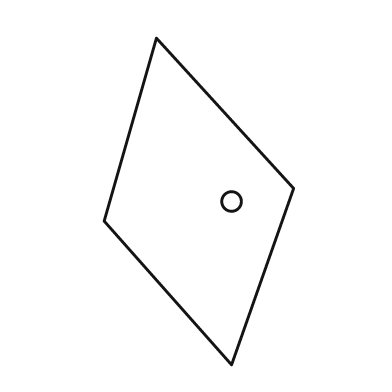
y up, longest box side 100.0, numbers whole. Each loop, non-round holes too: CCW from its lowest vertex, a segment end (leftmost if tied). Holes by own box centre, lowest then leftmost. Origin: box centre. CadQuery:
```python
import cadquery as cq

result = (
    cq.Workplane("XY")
    .moveTo(10.0, -50.0)
    .lineTo(29.0, 4.0)
    .lineTo(-13.0, 50.0)
    .lineTo(-29.0, -6.0)
    .close()
    .moveTo(10.0, 0.0)
    .circle(3.0)
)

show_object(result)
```